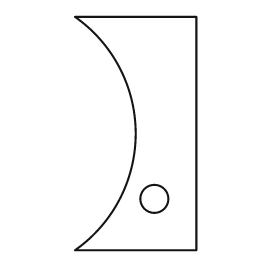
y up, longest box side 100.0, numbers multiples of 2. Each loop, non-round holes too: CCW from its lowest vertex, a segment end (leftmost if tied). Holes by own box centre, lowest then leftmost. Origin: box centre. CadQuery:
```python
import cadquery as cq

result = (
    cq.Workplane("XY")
    .moveTo(-26.0, -50.0)
    .lineTo(26.0, -50.0)
    .lineTo(26.0, 50.0)
    .lineTo(-26.0, 50.0)
    .threePointArc((0.0, 0.0), (-26.0, -50.0))
    .close()
    .moveTo(8.0, -28.0)
    .circle(6.0)
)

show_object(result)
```